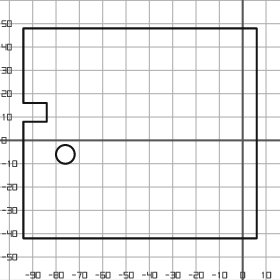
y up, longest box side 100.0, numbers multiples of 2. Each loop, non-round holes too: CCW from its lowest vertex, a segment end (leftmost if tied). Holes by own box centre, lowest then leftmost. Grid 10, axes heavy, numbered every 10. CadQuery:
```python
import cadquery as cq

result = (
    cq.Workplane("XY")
    .moveTo(-94.0, -42.0)
    .lineTo(6.0, -42.0)
    .lineTo(6.0, 48.0)
    .lineTo(-94.0, 48.0)
    .lineTo(-94.0, 16.0)
    .lineTo(-84.0, 16.0)
    .lineTo(-84.0, 8.0)
    .lineTo(-94.0, 8.0)
    .close()
    .moveTo(-76.0, -6.0)
    .circle(4.0)
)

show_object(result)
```